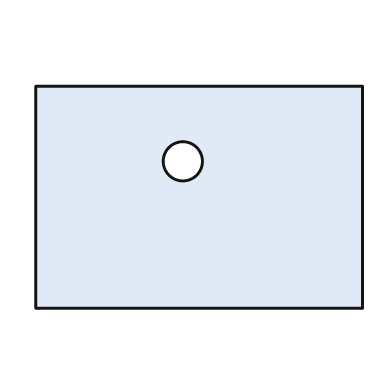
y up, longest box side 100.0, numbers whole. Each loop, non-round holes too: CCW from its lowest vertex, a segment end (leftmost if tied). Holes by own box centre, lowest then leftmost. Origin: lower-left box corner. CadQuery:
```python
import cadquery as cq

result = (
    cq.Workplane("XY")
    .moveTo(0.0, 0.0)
    .lineTo(100.0, 0.0)
    .lineTo(100.0, 68.0)
    .lineTo(0.0, 68.0)
    .close()
    .moveTo(45.0, 45.0)
    .circle(6.0)
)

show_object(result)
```